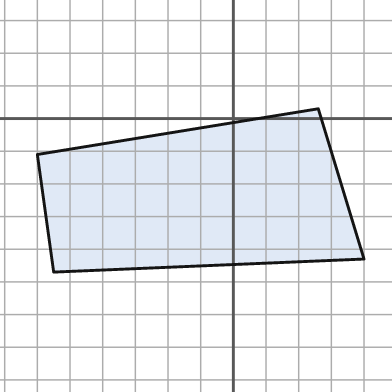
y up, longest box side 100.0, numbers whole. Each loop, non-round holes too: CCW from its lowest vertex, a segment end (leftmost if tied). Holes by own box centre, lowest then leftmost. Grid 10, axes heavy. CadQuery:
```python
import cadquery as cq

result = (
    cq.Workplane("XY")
    .moveTo(-55.0, -47.0)
    .lineTo(40.0, -43.0)
    .lineTo(26.0, 3.0)
    .lineTo(-60.0, -11.0)
    .close()
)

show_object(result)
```